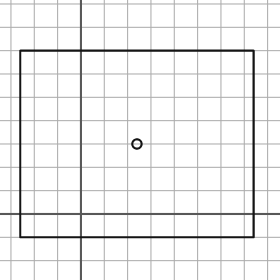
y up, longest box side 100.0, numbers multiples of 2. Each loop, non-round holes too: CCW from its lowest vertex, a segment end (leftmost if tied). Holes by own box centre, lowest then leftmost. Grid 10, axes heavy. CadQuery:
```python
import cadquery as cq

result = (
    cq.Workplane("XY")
    .moveTo(-26.0, -10.0)
    .lineTo(74.0, -10.0)
    .lineTo(74.0, 70.0)
    .lineTo(-26.0, 70.0)
    .close()
    .moveTo(24.0, 30.0)
    .circle(2.0)
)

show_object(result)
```